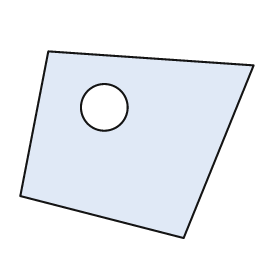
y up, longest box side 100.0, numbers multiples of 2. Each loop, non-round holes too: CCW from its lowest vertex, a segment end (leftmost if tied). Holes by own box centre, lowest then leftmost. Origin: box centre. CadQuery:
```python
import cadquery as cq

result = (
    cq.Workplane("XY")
    .moveTo(20.0, -40.0)
    .lineTo(50.0, 34.0)
    .lineTo(-38.0, 40.0)
    .lineTo(-50.0, -22.0)
    .close()
    .moveTo(-14.0, 16.0)
    .circle(10.0)
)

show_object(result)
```